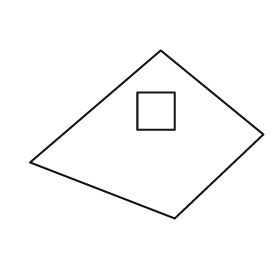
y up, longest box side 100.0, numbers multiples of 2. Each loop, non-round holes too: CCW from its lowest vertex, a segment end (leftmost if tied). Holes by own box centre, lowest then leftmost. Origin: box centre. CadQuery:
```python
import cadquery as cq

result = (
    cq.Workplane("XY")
    .moveTo(12.0, -36.0)
    .lineTo(50.0, 0.0)
    .lineTo(6.0, 36.0)
    .lineTo(-50.0, -12.0)
    .close()
    .moveTo(-4.0, 2.0)
    .lineTo(12.0, 2.0)
    .lineTo(12.0, 18.0)
    .lineTo(-4.0, 18.0)
    .close()
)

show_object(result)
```